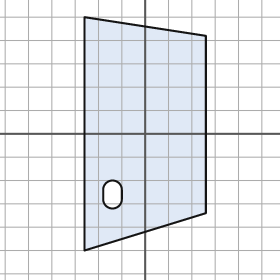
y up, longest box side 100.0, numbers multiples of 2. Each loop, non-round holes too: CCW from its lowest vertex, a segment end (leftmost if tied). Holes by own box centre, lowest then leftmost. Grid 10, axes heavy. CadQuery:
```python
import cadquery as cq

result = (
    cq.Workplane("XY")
    .moveTo(-26.0, -50.0)
    .lineTo(26.0, -34.0)
    .lineTo(26.0, 42.0)
    .lineTo(-26.0, 50.0)
    .close()
    .moveTo(-18.0, -28.0)
    .threePointArc((-14.0, -32.0), (-10.0, -28.0))
    .lineTo(-10.0, -24.0)
    .threePointArc((-14.0, -20.0), (-18.0, -24.0))
    .close()
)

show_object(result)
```